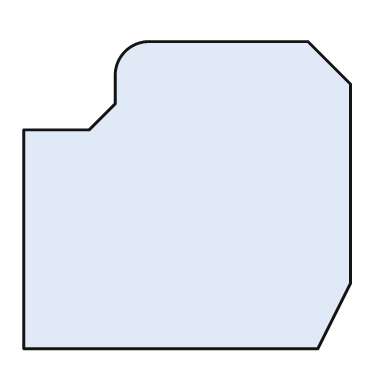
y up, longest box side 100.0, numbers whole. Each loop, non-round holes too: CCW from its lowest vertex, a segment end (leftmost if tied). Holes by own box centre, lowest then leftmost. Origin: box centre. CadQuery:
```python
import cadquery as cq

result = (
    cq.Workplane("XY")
    .moveTo(-50.0, -47.0)
    .lineTo(40.0, -47.0)
    .lineTo(50.0, -27.0)
    .lineTo(50.0, 34.0)
    .lineTo(37.0, 47.0)
    .lineTo(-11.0, 47.0)
    .threePointArc((-19.0, 44.0), (-22.0, 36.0))
    .lineTo(-22.0, 28.0)
    .lineTo(-30.0, 20.0)
    .lineTo(-50.0, 20.0)
    .close()
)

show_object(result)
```